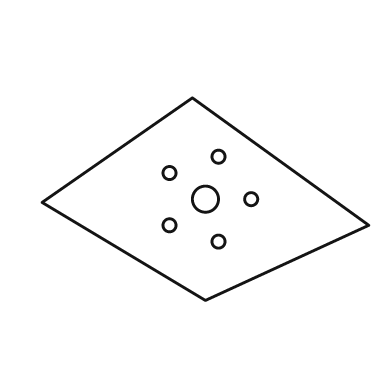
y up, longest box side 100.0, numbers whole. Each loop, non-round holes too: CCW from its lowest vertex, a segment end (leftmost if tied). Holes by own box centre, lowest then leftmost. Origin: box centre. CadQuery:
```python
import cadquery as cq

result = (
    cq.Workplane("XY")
    .moveTo(0.0, -31.0)
    .lineTo(50.0, -8.0)
    .lineTo(-4.0, 31.0)
    .lineTo(-50.0, -1.0)
    .close()
    .moveTo(4.0, -13.0)
    .circle(2.0)
    .moveTo(-11.0, -8.0)
    .circle(2.0)
    .moveTo(0.0, 0.0)
    .circle(4.0)
    .moveTo(14.0, 0.0)
    .circle(2.0)
    .moveTo(-11.0, 8.0)
    .circle(2.0)
    .moveTo(4.0, 13.0)
    .circle(2.0)
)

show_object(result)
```